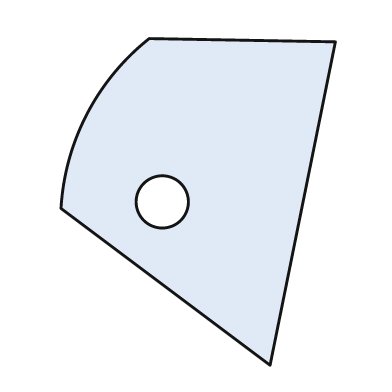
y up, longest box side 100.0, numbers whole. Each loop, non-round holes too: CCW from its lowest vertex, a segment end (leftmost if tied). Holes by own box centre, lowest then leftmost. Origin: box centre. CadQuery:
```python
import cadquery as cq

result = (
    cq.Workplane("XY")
    .moveTo(22.0, -50.0)
    .lineTo(42.0, 49.0)
    .lineTo(-15.0, 50.0)
    .threePointArc((-34.0, 27.0), (-42.0, -2.0))
    .close()
    .moveTo(-11.0, 0.0)
    .circle(8.0)
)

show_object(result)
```